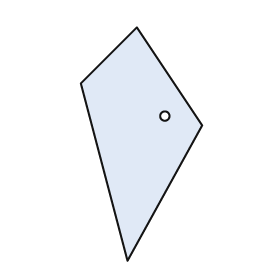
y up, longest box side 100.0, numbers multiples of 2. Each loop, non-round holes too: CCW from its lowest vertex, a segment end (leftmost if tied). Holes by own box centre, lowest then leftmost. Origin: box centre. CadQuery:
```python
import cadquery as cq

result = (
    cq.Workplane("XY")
    .moveTo(-6.0, -50.0)
    .lineTo(26.0, 8.0)
    .lineTo(-2.0, 50.0)
    .lineTo(-26.0, 26.0)
    .close()
    .moveTo(10.0, 12.0)
    .circle(2.0)
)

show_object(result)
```